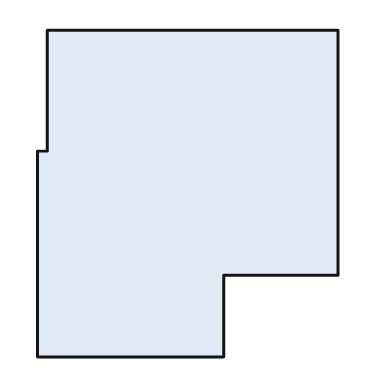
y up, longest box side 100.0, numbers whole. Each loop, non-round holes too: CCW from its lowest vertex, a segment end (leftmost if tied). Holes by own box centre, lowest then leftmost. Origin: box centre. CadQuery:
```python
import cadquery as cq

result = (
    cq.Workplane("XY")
    .moveTo(-46.0, -50.0)
    .lineTo(11.0, -50.0)
    .lineTo(11.0, -25.0)
    .lineTo(46.0, -25.0)
    .lineTo(46.0, 50.0)
    .lineTo(-43.0, 50.0)
    .lineTo(-43.0, 13.0)
    .lineTo(-46.0, 13.0)
    .close()
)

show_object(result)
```